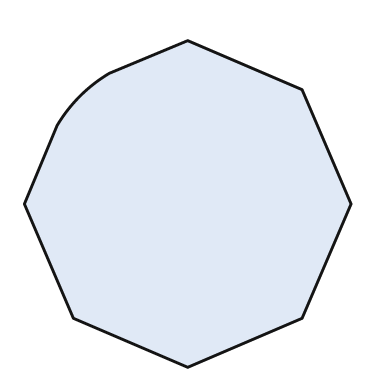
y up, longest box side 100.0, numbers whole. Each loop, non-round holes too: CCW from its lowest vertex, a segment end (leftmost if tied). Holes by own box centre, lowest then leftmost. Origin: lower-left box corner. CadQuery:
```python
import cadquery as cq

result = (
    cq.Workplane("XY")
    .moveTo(50.0, 0.0)
    .lineTo(85.0, 15.0)
    .lineTo(100.0, 50.0)
    .lineTo(85.0, 85.0)
    .lineTo(50.0, 100.0)
    .lineTo(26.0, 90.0)
    .threePointArc((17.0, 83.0), (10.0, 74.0))
    .lineTo(0.0, 50.0)
    .lineTo(15.0, 15.0)
    .close()
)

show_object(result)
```